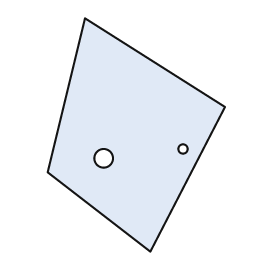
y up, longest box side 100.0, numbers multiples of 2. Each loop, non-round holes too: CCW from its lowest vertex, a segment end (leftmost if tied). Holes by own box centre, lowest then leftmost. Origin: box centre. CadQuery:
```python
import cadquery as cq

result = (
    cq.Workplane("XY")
    .moveTo(6.0, -50.0)
    .lineTo(38.0, 12.0)
    .lineTo(-22.0, 50.0)
    .lineTo(-38.0, -16.0)
    .close()
    .moveTo(-14.0, -10.0)
    .circle(4.0)
    .moveTo(20.0, -6.0)
    .circle(2.0)
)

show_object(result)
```